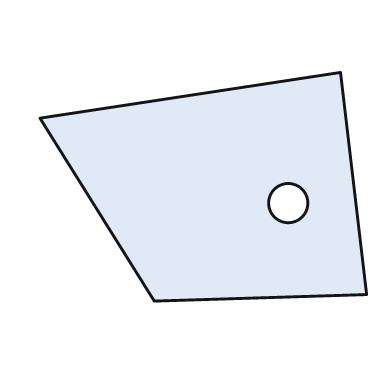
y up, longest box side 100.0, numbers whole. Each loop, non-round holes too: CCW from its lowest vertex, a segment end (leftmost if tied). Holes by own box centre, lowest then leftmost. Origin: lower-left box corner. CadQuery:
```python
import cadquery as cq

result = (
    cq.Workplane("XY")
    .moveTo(35.0, 0.0)
    .lineTo(100.0, 2.0)
    .lineTo(92.0, 70.0)
    .lineTo(0.0, 56.0)
    .close()
    .moveTo(76.0, 30.0)
    .circle(6.0)
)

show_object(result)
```